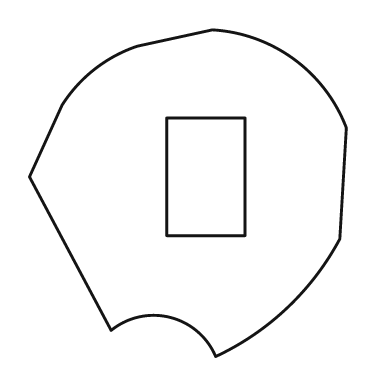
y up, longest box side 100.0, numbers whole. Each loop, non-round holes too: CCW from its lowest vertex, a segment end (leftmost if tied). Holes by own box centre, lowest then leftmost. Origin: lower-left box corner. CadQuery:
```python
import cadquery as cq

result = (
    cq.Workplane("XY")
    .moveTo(57.0, 0.0)
    .threePointArc((79.0, 15.0), (95.0, 36.0))
    .lineTo(97.0, 70.0)
    .threePointArc((81.0, 91.0), (56.0, 100.0))
    .lineTo(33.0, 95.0)
    .threePointArc((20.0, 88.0), (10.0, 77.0))
    .lineTo(0.0, 55.0)
    .lineTo(25.0, 8.0)
    .threePointArc((43.0, 12.0), (57.0, 0.0))
    .close()
    .moveTo(42.0, 37.0)
    .lineTo(66.0, 37.0)
    .lineTo(66.0, 73.0)
    .lineTo(42.0, 73.0)
    .close()
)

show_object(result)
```